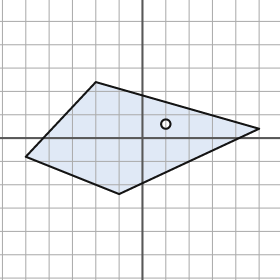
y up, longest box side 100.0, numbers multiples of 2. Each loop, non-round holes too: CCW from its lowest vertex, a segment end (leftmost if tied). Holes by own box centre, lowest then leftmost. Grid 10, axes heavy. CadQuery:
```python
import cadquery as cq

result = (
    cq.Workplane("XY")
    .moveTo(-10.0, -24.0)
    .lineTo(50.0, 4.0)
    .lineTo(-20.0, 24.0)
    .lineTo(-50.0, -8.0)
    .close()
    .moveTo(10.0, 6.0)
    .circle(2.0)
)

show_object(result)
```